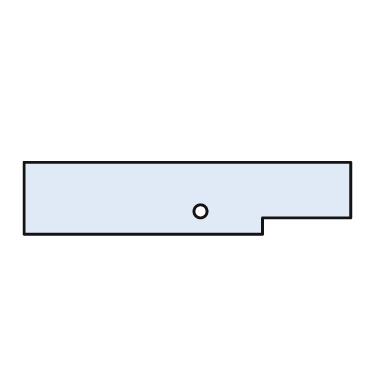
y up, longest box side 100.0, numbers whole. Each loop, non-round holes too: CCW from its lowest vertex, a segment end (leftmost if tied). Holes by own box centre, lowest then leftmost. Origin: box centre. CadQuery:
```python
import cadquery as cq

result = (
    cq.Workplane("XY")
    .moveTo(-50.0, -11.0)
    .lineTo(23.0, -11.0)
    .lineTo(23.0, -6.0)
    .lineTo(50.0, -6.0)
    .lineTo(50.0, 11.0)
    .lineTo(-50.0, 11.0)
    .close()
    .moveTo(4.0, -4.0)
    .circle(2.0)
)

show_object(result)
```